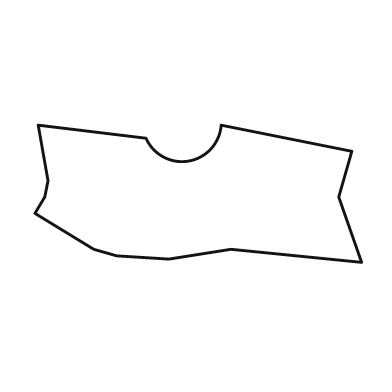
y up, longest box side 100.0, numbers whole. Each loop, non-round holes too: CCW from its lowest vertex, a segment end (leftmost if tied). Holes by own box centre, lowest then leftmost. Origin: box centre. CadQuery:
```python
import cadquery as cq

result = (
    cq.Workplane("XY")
    .moveTo(50.0, -21.0)
    .lineTo(43.0, -1.0)
    .lineTo(47.0, 13.0)
    .lineTo(7.0, 21.0)
    .threePointArc((-3.0, 10.0), (-16.0, 17.0))
    .lineTo(-49.0, 21.0)
    .lineTo(-46.0, 4.0)
    .lineTo(-47.0, -1.0)
    .lineTo(-50.0, -6.0)
    .lineTo(-32.0, -17.0)
    .lineTo(-25.0, -19.0)
    .lineTo(-9.0, -20.0)
    .lineTo(10.0, -17.0)
    .close()
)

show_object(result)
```